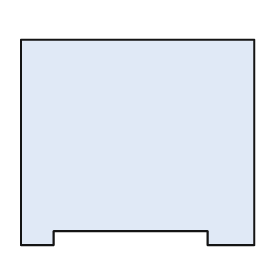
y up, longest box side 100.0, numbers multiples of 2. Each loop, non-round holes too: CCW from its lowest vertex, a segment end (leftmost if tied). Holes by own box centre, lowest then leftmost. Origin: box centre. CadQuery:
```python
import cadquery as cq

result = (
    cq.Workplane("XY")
    .moveTo(-50.0, -44.0)
    .lineTo(-36.0, -44.0)
    .lineTo(-36.0, -38.0)
    .lineTo(30.0, -38.0)
    .lineTo(30.0, -44.0)
    .lineTo(50.0, -44.0)
    .lineTo(50.0, 44.0)
    .lineTo(-50.0, 44.0)
    .close()
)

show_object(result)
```